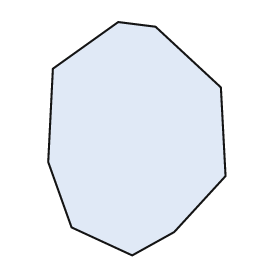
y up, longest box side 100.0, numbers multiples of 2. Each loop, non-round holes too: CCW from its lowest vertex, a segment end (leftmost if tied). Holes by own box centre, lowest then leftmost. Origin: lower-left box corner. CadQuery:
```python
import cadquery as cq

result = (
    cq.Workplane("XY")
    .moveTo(36.0, 0.0)
    .lineTo(54.0, 10.0)
    .lineTo(76.0, 34.0)
    .lineTo(74.0, 72.0)
    .lineTo(46.0, 98.0)
    .lineTo(30.0, 100.0)
    .lineTo(2.0, 80.0)
    .lineTo(0.0, 40.0)
    .lineTo(10.0, 12.0)
    .close()
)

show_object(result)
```